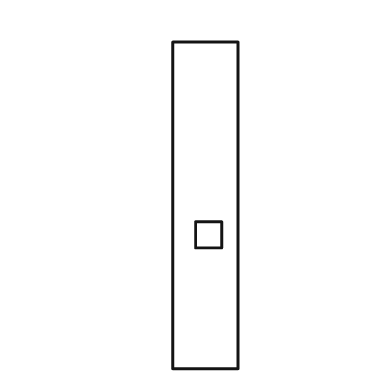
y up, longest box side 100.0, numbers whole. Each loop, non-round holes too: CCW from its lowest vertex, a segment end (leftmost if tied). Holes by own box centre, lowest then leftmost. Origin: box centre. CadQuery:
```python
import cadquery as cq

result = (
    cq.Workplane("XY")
    .moveTo(-10.0, -50.0)
    .lineTo(10.0, -50.0)
    .lineTo(10.0, 50.0)
    .lineTo(-10.0, 50.0)
    .close()
    .moveTo(-3.0, -13.0)
    .lineTo(5.0, -13.0)
    .lineTo(5.0, -5.0)
    .lineTo(-3.0, -5.0)
    .close()
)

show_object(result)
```